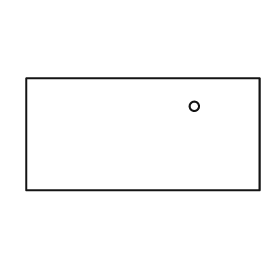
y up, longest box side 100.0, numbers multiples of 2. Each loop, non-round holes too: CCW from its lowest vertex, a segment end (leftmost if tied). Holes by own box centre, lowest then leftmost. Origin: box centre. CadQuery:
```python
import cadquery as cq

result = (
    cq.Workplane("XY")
    .moveTo(-50.0, -24.0)
    .lineTo(50.0, -24.0)
    .lineTo(50.0, 24.0)
    .lineTo(-50.0, 24.0)
    .close()
    .moveTo(22.0, 12.0)
    .circle(2.0)
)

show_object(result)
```